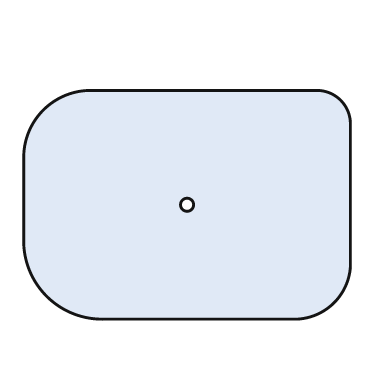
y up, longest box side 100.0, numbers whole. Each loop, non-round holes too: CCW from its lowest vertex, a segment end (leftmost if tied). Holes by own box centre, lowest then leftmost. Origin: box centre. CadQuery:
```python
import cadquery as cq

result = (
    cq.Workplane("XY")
    .moveTo(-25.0, -35.0)
    .lineTo(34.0, -35.0)
    .threePointArc((45.0, -30.0), (50.0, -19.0))
    .lineTo(50.0, 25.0)
    .threePointArc((47.0, 32.0), (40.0, 35.0))
    .lineTo(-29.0, 35.0)
    .threePointArc((-44.0, 29.0), (-50.0, 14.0))
    .lineTo(-50.0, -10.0)
    .threePointArc((-43.0, -28.0), (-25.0, -35.0))
    .close()
    .moveTo(0.0, 0.0)
    .circle(2.0)
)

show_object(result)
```